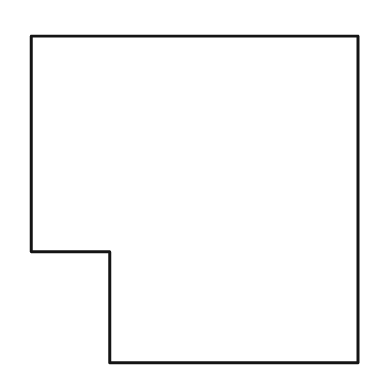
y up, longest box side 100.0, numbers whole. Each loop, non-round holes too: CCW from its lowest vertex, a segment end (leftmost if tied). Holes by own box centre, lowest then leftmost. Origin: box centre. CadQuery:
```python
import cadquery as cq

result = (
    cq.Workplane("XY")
    .moveTo(-26.0, -50.0)
    .lineTo(50.0, -50.0)
    .lineTo(50.0, 50.0)
    .lineTo(-50.0, 50.0)
    .lineTo(-50.0, -16.0)
    .lineTo(-26.0, -16.0)
    .close()
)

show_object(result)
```